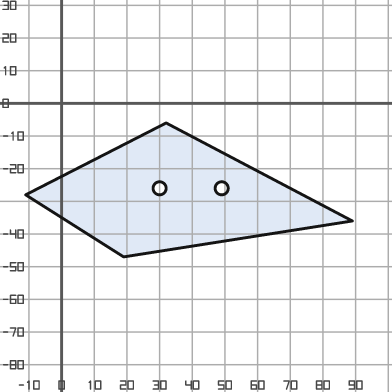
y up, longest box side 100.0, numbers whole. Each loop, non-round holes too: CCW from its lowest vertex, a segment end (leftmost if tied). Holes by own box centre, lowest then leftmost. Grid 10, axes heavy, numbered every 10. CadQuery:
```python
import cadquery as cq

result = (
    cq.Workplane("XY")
    .moveTo(19.0, -47.0)
    .lineTo(89.0, -36.0)
    .lineTo(32.0, -6.0)
    .lineTo(-11.0, -28.0)
    .close()
    .moveTo(30.0, -26.0)
    .circle(2.0)
    .moveTo(49.0, -26.0)
    .circle(2.0)
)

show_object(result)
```